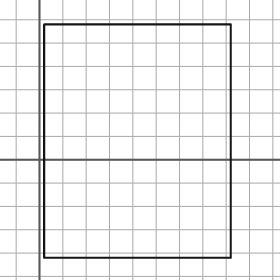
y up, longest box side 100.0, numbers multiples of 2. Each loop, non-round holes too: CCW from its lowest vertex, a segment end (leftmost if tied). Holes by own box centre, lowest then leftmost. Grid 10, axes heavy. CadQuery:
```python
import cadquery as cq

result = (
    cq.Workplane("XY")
    .moveTo(2.0, -42.0)
    .lineTo(82.0, -42.0)
    .lineTo(82.0, 58.0)
    .lineTo(2.0, 58.0)
    .close()
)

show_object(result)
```